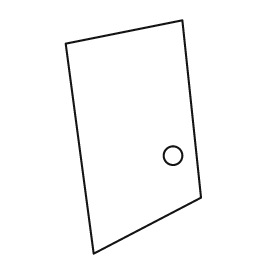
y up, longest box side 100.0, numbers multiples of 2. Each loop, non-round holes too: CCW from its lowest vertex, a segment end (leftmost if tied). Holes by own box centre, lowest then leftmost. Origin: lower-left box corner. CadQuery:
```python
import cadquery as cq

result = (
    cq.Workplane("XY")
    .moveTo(12.0, 0.0)
    .lineTo(58.0, 24.0)
    .lineTo(50.0, 100.0)
    .lineTo(0.0, 90.0)
    .close()
    .moveTo(46.0, 42.0)
    .circle(4.0)
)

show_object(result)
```